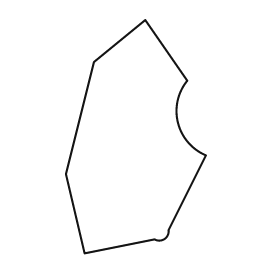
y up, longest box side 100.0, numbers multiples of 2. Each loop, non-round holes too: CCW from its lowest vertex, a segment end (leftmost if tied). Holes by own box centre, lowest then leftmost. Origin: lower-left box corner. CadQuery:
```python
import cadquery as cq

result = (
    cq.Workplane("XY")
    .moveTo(8.0, 0.0)
    .lineTo(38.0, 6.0)
    .threePointArc((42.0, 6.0), (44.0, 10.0))
    .lineTo(60.0, 42.0)
    .threePointArc((48.0, 56.0), (52.0, 74.0))
    .lineTo(34.0, 100.0)
    .lineTo(12.0, 82.0)
    .lineTo(0.0, 34.0)
    .close()
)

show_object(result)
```